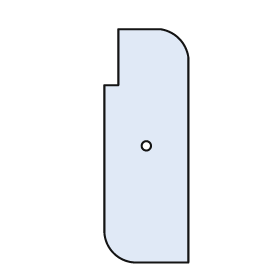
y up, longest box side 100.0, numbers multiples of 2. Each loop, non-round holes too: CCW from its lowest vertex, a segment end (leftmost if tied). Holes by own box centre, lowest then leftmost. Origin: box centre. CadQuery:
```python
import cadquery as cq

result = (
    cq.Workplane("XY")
    .moveTo(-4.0, -50.0)
    .lineTo(18.0, -50.0)
    .lineTo(18.0, 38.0)
    .threePointArc((14.0, 46.0), (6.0, 50.0))
    .lineTo(-12.0, 50.0)
    .lineTo(-12.0, 26.0)
    .lineTo(-18.0, 26.0)
    .lineTo(-18.0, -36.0)
    .threePointArc((-14.0, -46.0), (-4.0, -50.0))
    .close()
    .moveTo(0.0, 0.0)
    .circle(2.0)
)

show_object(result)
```